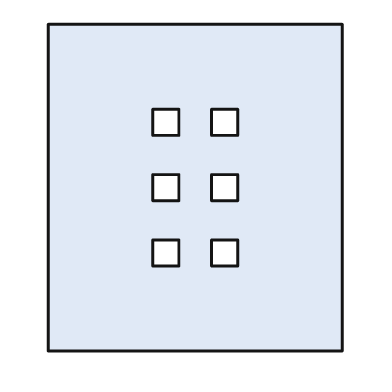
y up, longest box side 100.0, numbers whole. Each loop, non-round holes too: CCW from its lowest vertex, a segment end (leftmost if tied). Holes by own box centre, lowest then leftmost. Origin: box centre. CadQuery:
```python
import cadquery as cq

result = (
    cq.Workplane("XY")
    .moveTo(-45.0, -50.0)
    .lineTo(45.0, -50.0)
    .lineTo(45.0, 50.0)
    .lineTo(-45.0, 50.0)
    .close()
    .moveTo(-13.0, -24.0)
    .lineTo(-5.0, -24.0)
    .lineTo(-5.0, -16.0)
    .lineTo(-13.0, -16.0)
    .close()
    .moveTo(5.0, -24.0)
    .lineTo(13.0, -24.0)
    .lineTo(13.0, -16.0)
    .lineTo(5.0, -16.0)
    .close()
    .moveTo(-13.0, -4.0)
    .lineTo(-5.0, -4.0)
    .lineTo(-5.0, 4.0)
    .lineTo(-13.0, 4.0)
    .close()
    .moveTo(5.0, -4.0)
    .lineTo(13.0, -4.0)
    .lineTo(13.0, 4.0)
    .lineTo(5.0, 4.0)
    .close()
    .moveTo(-13.0, 16.0)
    .lineTo(-5.0, 16.0)
    .lineTo(-5.0, 24.0)
    .lineTo(-13.0, 24.0)
    .close()
    .moveTo(5.0, 16.0)
    .lineTo(13.0, 16.0)
    .lineTo(13.0, 24.0)
    .lineTo(5.0, 24.0)
    .close()
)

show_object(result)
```